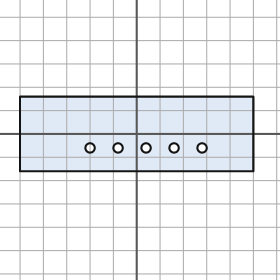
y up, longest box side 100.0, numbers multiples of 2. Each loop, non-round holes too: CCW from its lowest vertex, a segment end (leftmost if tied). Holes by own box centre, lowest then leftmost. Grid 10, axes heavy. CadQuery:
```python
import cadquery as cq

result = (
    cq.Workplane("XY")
    .moveTo(-50.0, -16.0)
    .lineTo(50.0, -16.0)
    .lineTo(50.0, 16.0)
    .lineTo(-50.0, 16.0)
    .close()
    .moveTo(-20.0, -6.0)
    .circle(2.0)
    .moveTo(-8.0, -6.0)
    .circle(2.0)
    .moveTo(4.0, -6.0)
    .circle(2.0)
    .moveTo(16.0, -6.0)
    .circle(2.0)
    .moveTo(28.0, -6.0)
    .circle(2.0)
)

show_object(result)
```